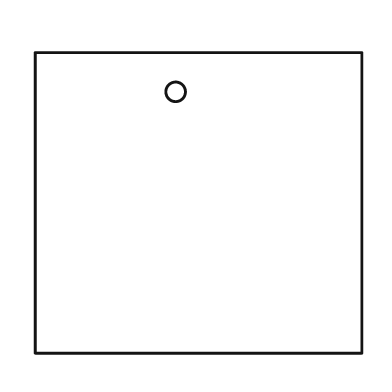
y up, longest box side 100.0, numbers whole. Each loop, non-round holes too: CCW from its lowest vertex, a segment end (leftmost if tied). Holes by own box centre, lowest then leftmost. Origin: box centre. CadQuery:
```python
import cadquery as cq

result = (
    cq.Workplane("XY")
    .moveTo(-50.0, -46.0)
    .lineTo(50.0, -46.0)
    .lineTo(50.0, 46.0)
    .lineTo(-50.0, 46.0)
    .close()
    .moveTo(-7.0, 34.0)
    .circle(3.0)
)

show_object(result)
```